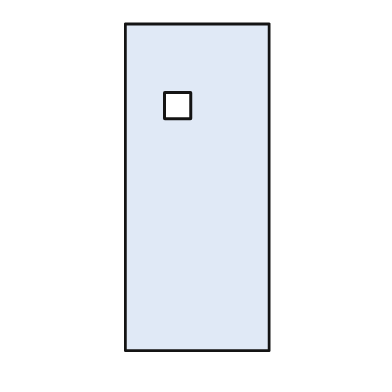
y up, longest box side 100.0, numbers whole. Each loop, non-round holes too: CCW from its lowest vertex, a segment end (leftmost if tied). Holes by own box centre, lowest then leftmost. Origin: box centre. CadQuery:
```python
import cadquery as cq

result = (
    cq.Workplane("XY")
    .moveTo(-22.0, -50.0)
    .lineTo(22.0, -50.0)
    .lineTo(22.0, 50.0)
    .lineTo(-22.0, 50.0)
    .close()
    .moveTo(-10.0, 21.0)
    .lineTo(-2.0, 21.0)
    .lineTo(-2.0, 29.0)
    .lineTo(-10.0, 29.0)
    .close()
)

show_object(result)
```